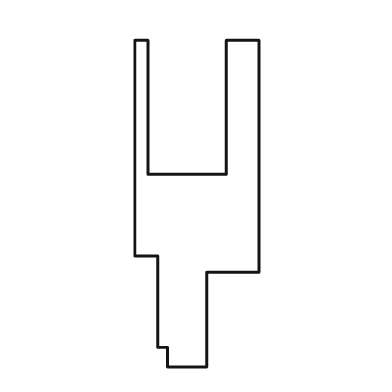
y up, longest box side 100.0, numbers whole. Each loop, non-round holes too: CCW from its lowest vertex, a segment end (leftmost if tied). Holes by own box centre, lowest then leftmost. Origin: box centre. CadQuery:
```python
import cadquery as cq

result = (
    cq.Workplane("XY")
    .moveTo(-9.0, -50.0)
    .lineTo(3.0, -50.0)
    .lineTo(3.0, -21.0)
    .lineTo(19.0, -21.0)
    .lineTo(19.0, 50.0)
    .lineTo(9.0, 50.0)
    .lineTo(9.0, 9.0)
    .lineTo(-15.0, 9.0)
    .lineTo(-15.0, 50.0)
    .lineTo(-19.0, 50.0)
    .lineTo(-19.0, -16.0)
    .lineTo(-12.0, -16.0)
    .lineTo(-12.0, -44.0)
    .lineTo(-9.0, -44.0)
    .close()
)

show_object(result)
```